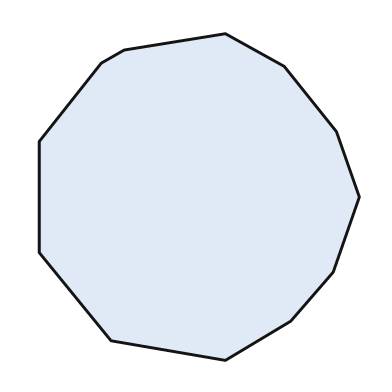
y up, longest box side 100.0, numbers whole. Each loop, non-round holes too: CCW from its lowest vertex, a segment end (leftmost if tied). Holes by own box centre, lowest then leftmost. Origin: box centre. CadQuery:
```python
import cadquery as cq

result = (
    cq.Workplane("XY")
    .moveTo(8.0, -50.0)
    .lineTo(28.0, -38.0)
    .lineTo(41.0, -23.0)
    .lineTo(49.0, 0.0)
    .lineTo(42.0, 20.0)
    .lineTo(26.0, 40.0)
    .lineTo(8.0, 50.0)
    .lineTo(-23.0, 45.0)
    .lineTo(-30.0, 41.0)
    .lineTo(-49.0, 17.0)
    .lineTo(-49.0, -17.0)
    .lineTo(-27.0, -44.0)
    .close()
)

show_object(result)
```